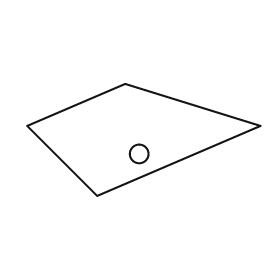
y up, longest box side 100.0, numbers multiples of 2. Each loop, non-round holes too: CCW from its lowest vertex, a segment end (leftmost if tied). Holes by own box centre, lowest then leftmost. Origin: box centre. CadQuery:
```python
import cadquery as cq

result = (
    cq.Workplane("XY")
    .moveTo(-20.0, -24.0)
    .lineTo(50.0, 6.0)
    .lineTo(-8.0, 24.0)
    .lineTo(-50.0, 6.0)
    .close()
    .moveTo(-2.0, -6.0)
    .circle(4.0)
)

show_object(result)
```